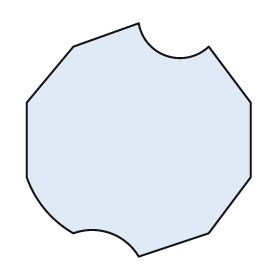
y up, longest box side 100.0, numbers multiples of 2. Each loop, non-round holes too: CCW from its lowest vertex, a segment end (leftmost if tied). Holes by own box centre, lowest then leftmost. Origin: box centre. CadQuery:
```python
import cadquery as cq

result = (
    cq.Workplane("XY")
    .moveTo(0.0, -50.0)
    .lineTo(30.0, -40.0)
    .lineTo(48.0, -16.0)
    .lineTo(48.0, 16.0)
    .lineTo(30.0, 40.0)
    .threePointArc((12.0, 36.0), (0.0, 50.0))
    .lineTo(-28.0, 40.0)
    .lineTo(-48.0, 16.0)
    .lineTo(-48.0, -16.0)
    .threePointArc((-40.0, -30.0), (-28.0, -40.0))
    .threePointArc((-12.0, -40.0), (0.0, -50.0))
    .close()
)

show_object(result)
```